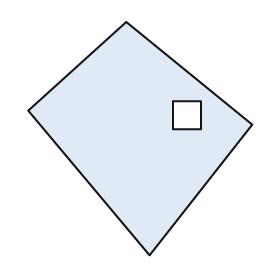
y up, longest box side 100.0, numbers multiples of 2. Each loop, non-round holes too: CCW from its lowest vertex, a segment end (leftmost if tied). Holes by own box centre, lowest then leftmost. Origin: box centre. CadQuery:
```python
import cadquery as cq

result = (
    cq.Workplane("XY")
    .moveTo(4.0, -50.0)
    .lineTo(48.0, 6.0)
    .lineTo(-6.0, 50.0)
    .lineTo(-48.0, 12.0)
    .close()
    .moveTo(14.0, 4.0)
    .lineTo(26.0, 4.0)
    .lineTo(26.0, 16.0)
    .lineTo(14.0, 16.0)
    .close()
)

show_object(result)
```